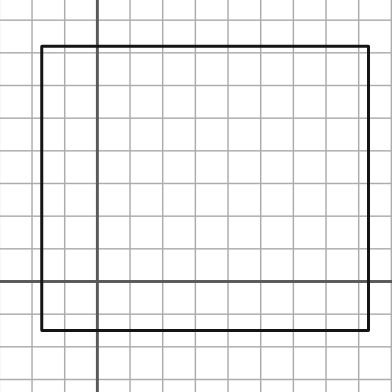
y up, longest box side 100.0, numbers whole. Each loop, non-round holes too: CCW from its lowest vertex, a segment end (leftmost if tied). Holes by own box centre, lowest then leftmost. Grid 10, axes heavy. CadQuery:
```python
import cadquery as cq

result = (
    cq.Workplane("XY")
    .moveTo(-17.0, -15.0)
    .lineTo(83.0, -15.0)
    .lineTo(83.0, 72.0)
    .lineTo(-17.0, 72.0)
    .close()
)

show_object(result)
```